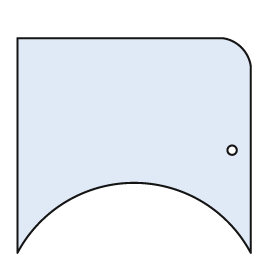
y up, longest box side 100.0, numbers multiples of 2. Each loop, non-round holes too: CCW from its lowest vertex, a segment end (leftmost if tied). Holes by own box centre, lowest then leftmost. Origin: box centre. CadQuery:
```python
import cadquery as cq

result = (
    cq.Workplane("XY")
    .moveTo(-50.0, -46.0)
    .threePointArc((0.0, -16.0), (50.0, -46.0))
    .lineTo(50.0, 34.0)
    .threePointArc((46.0, 42.0), (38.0, 46.0))
    .lineTo(-50.0, 46.0)
    .close()
    .moveTo(42.0, -2.0)
    .circle(2.0)
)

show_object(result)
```